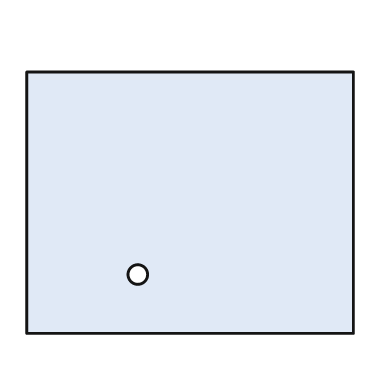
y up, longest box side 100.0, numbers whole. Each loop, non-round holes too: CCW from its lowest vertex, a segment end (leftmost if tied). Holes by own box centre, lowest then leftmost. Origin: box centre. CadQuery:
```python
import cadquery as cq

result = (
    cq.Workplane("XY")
    .moveTo(-50.0, -40.0)
    .lineTo(50.0, -40.0)
    .lineTo(50.0, 40.0)
    .lineTo(-50.0, 40.0)
    .close()
    .moveTo(-16.0, -22.0)
    .circle(3.0)
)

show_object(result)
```